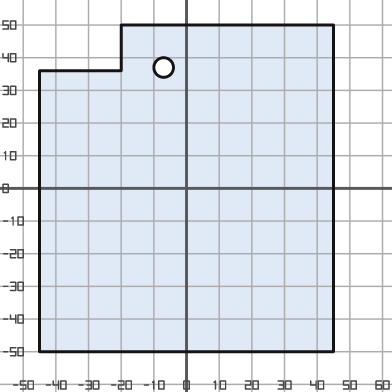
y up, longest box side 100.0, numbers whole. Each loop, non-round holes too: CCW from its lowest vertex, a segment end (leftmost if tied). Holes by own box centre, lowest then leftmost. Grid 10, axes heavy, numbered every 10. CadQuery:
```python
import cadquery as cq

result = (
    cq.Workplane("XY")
    .moveTo(-45.0, -50.0)
    .lineTo(45.0, -50.0)
    .lineTo(45.0, 50.0)
    .lineTo(-20.0, 50.0)
    .lineTo(-20.0, 36.0)
    .lineTo(-45.0, 36.0)
    .close()
    .moveTo(-7.0, 37.0)
    .circle(3.0)
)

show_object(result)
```